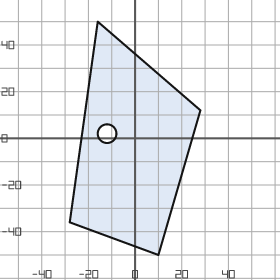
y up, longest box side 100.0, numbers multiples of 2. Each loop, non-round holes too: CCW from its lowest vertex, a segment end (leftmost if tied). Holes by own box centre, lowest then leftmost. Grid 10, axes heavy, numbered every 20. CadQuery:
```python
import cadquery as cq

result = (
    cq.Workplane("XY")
    .moveTo(10.0, -50.0)
    .lineTo(28.0, 12.0)
    .lineTo(-16.0, 50.0)
    .lineTo(-28.0, -36.0)
    .close()
    .moveTo(-12.0, 2.0)
    .circle(4.0)
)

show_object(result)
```